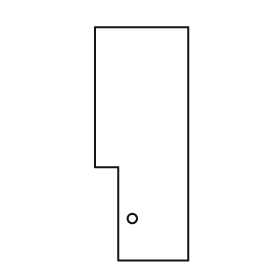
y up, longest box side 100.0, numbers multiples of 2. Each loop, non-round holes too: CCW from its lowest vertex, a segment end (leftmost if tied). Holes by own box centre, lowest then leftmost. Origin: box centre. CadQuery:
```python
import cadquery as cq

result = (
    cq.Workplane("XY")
    .moveTo(-10.0, -50.0)
    .lineTo(20.0, -50.0)
    .lineTo(20.0, 50.0)
    .lineTo(-20.0, 50.0)
    .lineTo(-20.0, -10.0)
    .lineTo(-10.0, -10.0)
    .close()
    .moveTo(-4.0, -32.0)
    .circle(2.0)
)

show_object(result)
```